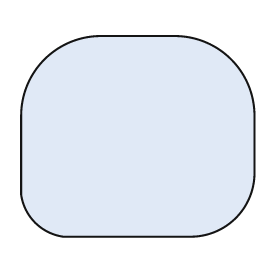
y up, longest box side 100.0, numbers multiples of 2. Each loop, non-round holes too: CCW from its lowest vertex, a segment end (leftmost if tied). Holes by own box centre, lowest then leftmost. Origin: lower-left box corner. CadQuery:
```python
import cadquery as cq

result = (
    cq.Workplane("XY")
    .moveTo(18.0, 0.0)
    .lineTo(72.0, 0.0)
    .threePointArc((92.0, 8.0), (100.0, 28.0))
    .lineTo(100.0, 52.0)
    .threePointArc((90.0, 76.0), (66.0, 86.0))
    .lineTo(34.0, 86.0)
    .threePointArc((10.0, 76.0), (0.0, 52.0))
    .lineTo(0.0, 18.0)
    .threePointArc((6.0, 6.0), (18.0, 0.0))
    .close()
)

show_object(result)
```